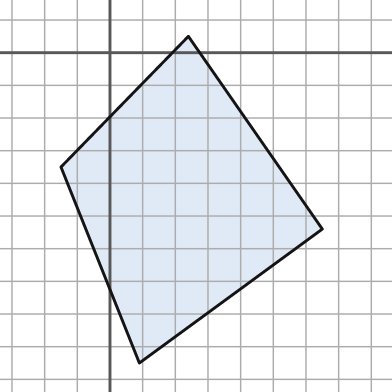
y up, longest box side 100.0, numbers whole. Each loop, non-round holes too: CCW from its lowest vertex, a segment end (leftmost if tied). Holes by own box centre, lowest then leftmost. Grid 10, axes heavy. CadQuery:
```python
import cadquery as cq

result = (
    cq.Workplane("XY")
    .moveTo(9.0, -95.0)
    .lineTo(65.0, -54.0)
    .lineTo(24.0, 5.0)
    .lineTo(-15.0, -35.0)
    .close()
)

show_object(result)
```